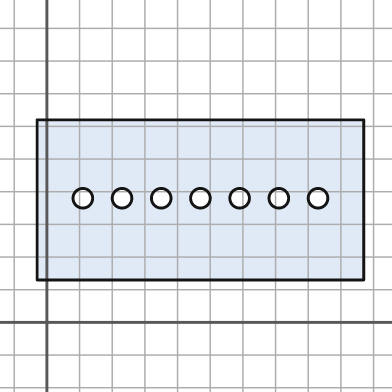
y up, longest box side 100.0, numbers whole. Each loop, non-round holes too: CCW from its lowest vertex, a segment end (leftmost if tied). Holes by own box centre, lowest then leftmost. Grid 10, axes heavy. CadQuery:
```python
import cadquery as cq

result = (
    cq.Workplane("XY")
    .moveTo(-3.0, 13.0)
    .lineTo(97.0, 13.0)
    .lineTo(97.0, 62.0)
    .lineTo(-3.0, 62.0)
    .close()
    .moveTo(11.0, 38.0)
    .circle(3.0)
    .moveTo(23.0, 38.0)
    .circle(3.0)
    .moveTo(35.0, 38.0)
    .circle(3.0)
    .moveTo(47.0, 38.0)
    .circle(3.0)
    .moveTo(59.0, 38.0)
    .circle(3.0)
    .moveTo(71.0, 38.0)
    .circle(3.0)
    .moveTo(83.0, 38.0)
    .circle(3.0)
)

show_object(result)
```